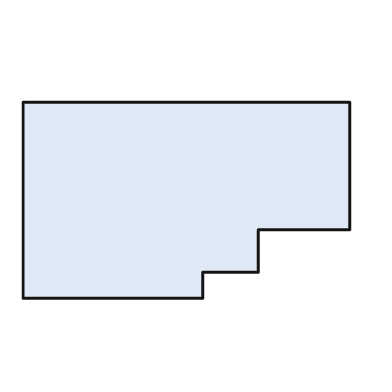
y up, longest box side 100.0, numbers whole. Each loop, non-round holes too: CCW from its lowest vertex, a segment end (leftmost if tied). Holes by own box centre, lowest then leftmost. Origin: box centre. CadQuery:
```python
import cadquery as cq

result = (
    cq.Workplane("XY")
    .moveTo(-50.0, -30.0)
    .lineTo(5.0, -30.0)
    .lineTo(5.0, -22.0)
    .lineTo(22.0, -22.0)
    .lineTo(22.0, -9.0)
    .lineTo(50.0, -9.0)
    .lineTo(50.0, 30.0)
    .lineTo(-50.0, 30.0)
    .close()
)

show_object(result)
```